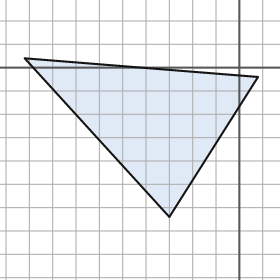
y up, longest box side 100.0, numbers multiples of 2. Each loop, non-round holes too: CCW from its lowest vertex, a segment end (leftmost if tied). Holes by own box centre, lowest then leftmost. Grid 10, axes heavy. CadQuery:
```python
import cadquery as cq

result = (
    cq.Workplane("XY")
    .moveTo(-30.0, -64.0)
    .lineTo(8.0, -4.0)
    .lineTo(-92.0, 4.0)
    .close()
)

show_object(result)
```